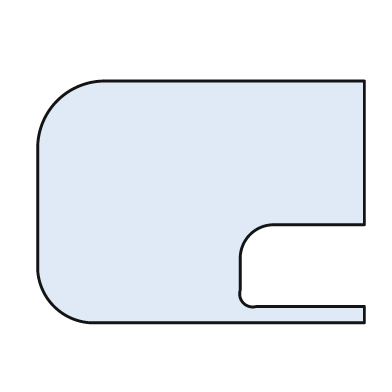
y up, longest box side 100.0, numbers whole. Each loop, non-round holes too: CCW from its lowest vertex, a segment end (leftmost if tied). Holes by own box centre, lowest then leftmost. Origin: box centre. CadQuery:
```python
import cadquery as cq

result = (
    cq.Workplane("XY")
    .moveTo(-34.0, -37.0)
    .lineTo(50.0, -37.0)
    .lineTo(50.0, -32.0)
    .lineTo(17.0, -32.0)
    .threePointArc((13.0, -31.0), (12.0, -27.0))
    .lineTo(12.0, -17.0)
    .threePointArc((15.0, -10.0), (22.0, -7.0))
    .lineTo(50.0, -7.0)
    .lineTo(50.0, 37.0)
    .lineTo(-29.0, 37.0)
    .threePointArc((-44.0, 31.0), (-50.0, 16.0))
    .lineTo(-50.0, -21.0)
    .threePointArc((-45.0, -32.0), (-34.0, -37.0))
    .close()
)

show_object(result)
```